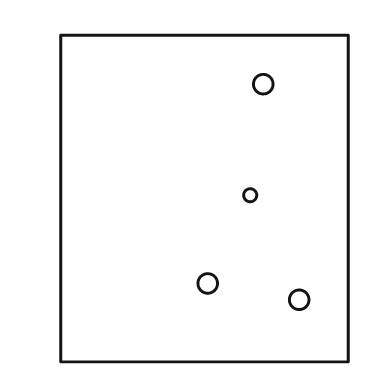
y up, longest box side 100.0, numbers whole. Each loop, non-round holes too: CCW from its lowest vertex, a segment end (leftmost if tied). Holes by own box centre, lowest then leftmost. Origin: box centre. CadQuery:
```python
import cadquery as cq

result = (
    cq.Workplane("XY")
    .moveTo(-44.0, -50.0)
    .lineTo(44.0, -50.0)
    .lineTo(44.0, 50.0)
    .lineTo(-44.0, 50.0)
    .close()
    .moveTo(29.0, -31.0)
    .circle(3.0)
    .moveTo(1.0, -26.0)
    .circle(3.0)
    .moveTo(14.0, 1.0)
    .circle(2.0)
    .moveTo(18.0, 35.0)
    .circle(3.0)
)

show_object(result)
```